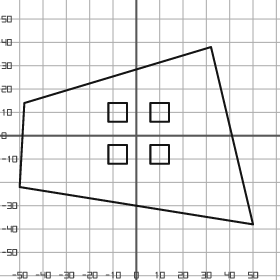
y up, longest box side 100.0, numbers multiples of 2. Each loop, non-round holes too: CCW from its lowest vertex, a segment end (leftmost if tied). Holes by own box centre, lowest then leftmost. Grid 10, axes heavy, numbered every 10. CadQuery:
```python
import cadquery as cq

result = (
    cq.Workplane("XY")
    .moveTo(50.0, -38.0)
    .lineTo(32.0, 38.0)
    .lineTo(-48.0, 14.0)
    .lineTo(-50.0, -22.0)
    .close()
    .moveTo(-12.0, -12.0)
    .lineTo(-4.0, -12.0)
    .lineTo(-4.0, -4.0)
    .lineTo(-12.0, -4.0)
    .close()
    .moveTo(6.0, -12.0)
    .lineTo(14.0, -12.0)
    .lineTo(14.0, -4.0)
    .lineTo(6.0, -4.0)
    .close()
    .moveTo(-12.0, 6.0)
    .lineTo(-4.0, 6.0)
    .lineTo(-4.0, 14.0)
    .lineTo(-12.0, 14.0)
    .close()
    .moveTo(6.0, 6.0)
    .lineTo(14.0, 6.0)
    .lineTo(14.0, 14.0)
    .lineTo(6.0, 14.0)
    .close()
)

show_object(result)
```